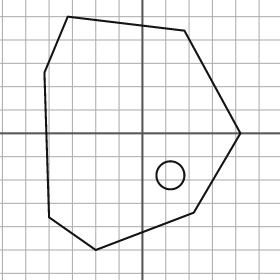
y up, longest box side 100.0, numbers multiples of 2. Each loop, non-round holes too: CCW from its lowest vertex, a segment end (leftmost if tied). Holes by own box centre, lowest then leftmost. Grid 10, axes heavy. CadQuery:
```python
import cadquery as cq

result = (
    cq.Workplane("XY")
    .moveTo(-20.0, -50.0)
    .lineTo(22.0, -34.0)
    .lineTo(42.0, 0.0)
    .lineTo(18.0, 44.0)
    .lineTo(-32.0, 50.0)
    .lineTo(-42.0, 26.0)
    .lineTo(-40.0, -36.0)
    .close()
    .moveTo(12.0, -18.0)
    .circle(6.0)
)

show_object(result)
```